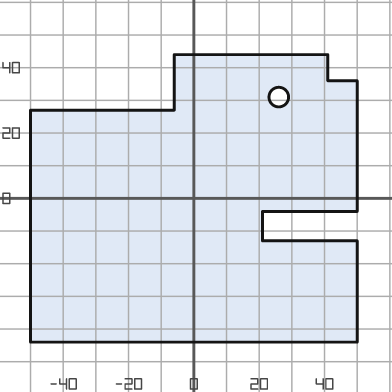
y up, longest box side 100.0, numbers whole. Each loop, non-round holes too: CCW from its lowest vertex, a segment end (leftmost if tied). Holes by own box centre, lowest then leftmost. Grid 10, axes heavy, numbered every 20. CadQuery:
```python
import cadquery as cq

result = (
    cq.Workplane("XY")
    .moveTo(-50.0, -44.0)
    .lineTo(50.0, -44.0)
    .lineTo(50.0, -13.0)
    .lineTo(21.0, -13.0)
    .lineTo(21.0, -4.0)
    .lineTo(50.0, -4.0)
    .lineTo(50.0, 36.0)
    .lineTo(41.0, 36.0)
    .lineTo(41.0, 44.0)
    .lineTo(-6.0, 44.0)
    .lineTo(-6.0, 27.0)
    .lineTo(-50.0, 27.0)
    .close()
    .moveTo(26.0, 31.0)
    .circle(3.0)
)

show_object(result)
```